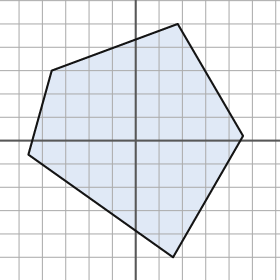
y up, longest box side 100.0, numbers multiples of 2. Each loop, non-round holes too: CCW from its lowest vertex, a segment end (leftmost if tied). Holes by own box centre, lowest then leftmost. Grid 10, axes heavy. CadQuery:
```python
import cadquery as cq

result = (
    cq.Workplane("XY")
    .moveTo(16.0, -50.0)
    .lineTo(46.0, 2.0)
    .lineTo(18.0, 50.0)
    .lineTo(-36.0, 30.0)
    .lineTo(-46.0, -6.0)
    .close()
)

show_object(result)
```